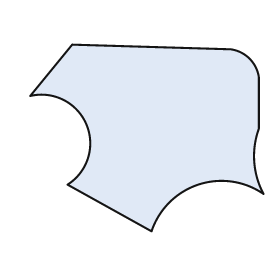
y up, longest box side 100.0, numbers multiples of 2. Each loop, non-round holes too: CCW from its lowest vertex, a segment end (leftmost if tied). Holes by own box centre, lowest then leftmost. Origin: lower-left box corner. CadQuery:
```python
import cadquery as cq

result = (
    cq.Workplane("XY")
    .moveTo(52.0, 0.0)
    .threePointArc((72.0, 20.0), (100.0, 16.0))
    .threePointArc((96.0, 30.0), (98.0, 44.0))
    .lineTo(98.0, 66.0)
    .threePointArc((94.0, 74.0), (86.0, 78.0))
    .lineTo(18.0, 80.0)
    .lineTo(0.0, 58.0)
    .threePointArc((24.0, 46.0), (16.0, 20.0))
    .close()
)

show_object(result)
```